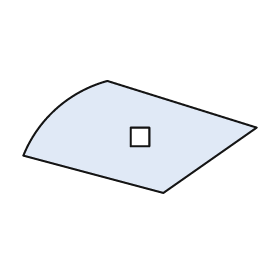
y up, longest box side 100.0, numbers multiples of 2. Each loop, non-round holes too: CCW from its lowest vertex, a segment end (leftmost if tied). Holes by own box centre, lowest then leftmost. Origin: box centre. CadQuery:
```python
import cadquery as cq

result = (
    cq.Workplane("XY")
    .moveTo(10.0, -24.0)
    .lineTo(50.0, 4.0)
    .lineTo(-14.0, 24.0)
    .threePointArc((-36.0, 12.0), (-50.0, -8.0))
    .close()
    .moveTo(-4.0, -4.0)
    .lineTo(4.0, -4.0)
    .lineTo(4.0, 4.0)
    .lineTo(-4.0, 4.0)
    .close()
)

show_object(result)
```